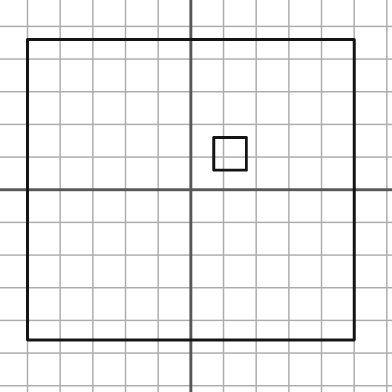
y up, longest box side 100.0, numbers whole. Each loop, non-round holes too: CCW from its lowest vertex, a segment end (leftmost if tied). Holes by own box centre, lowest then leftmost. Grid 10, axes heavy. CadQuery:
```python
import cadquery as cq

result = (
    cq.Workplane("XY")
    .moveTo(-50.0, -46.0)
    .lineTo(50.0, -46.0)
    .lineTo(50.0, 46.0)
    .lineTo(-50.0, 46.0)
    .close()
    .moveTo(7.0, 6.0)
    .lineTo(17.0, 6.0)
    .lineTo(17.0, 16.0)
    .lineTo(7.0, 16.0)
    .close()
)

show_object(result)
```